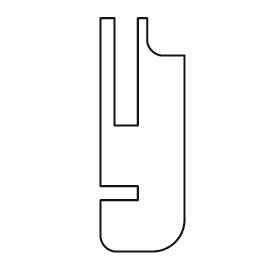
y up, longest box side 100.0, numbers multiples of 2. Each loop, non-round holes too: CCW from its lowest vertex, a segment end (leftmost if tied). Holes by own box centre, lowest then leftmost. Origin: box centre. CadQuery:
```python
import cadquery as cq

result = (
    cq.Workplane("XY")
    .moveTo(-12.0, -50.0)
    .lineTo(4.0, -50.0)
    .threePointArc((14.0, -46.0), (18.0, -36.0))
    .lineTo(18.0, 34.0)
    .lineTo(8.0, 34.0)
    .threePointArc((4.0, 36.0), (2.0, 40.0))
    .lineTo(2.0, 50.0)
    .lineTo(-2.0, 50.0)
    .lineTo(-2.0, 4.0)
    .lineTo(-12.0, 4.0)
    .lineTo(-12.0, 50.0)
    .lineTo(-18.0, 50.0)
    .lineTo(-18.0, -22.0)
    .lineTo(-2.0, -22.0)
    .lineTo(-2.0, -28.0)
    .lineTo(-18.0, -28.0)
    .lineTo(-18.0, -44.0)
    .threePointArc((-16.0, -48.0), (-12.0, -50.0))
    .close()
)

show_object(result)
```